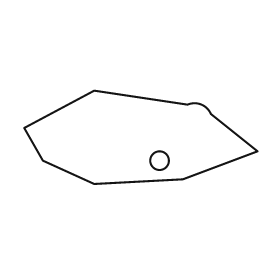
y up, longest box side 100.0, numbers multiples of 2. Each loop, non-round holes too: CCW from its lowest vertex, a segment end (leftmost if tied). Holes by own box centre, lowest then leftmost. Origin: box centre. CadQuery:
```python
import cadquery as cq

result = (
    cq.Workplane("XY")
    .moveTo(-20.0, -20.0)
    .lineTo(18.0, -18.0)
    .lineTo(50.0, -6.0)
    .lineTo(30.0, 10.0)
    .threePointArc((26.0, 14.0), (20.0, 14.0))
    .lineTo(-20.0, 20.0)
    .lineTo(-50.0, 4.0)
    .lineTo(-42.0, -10.0)
    .close()
    .moveTo(8.0, -10.0)
    .circle(4.0)
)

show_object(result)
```